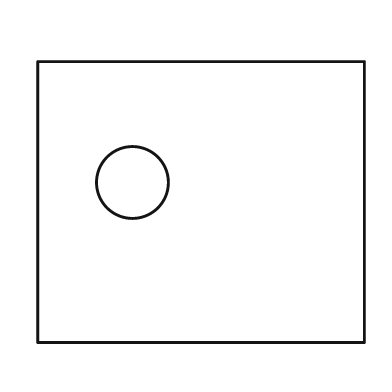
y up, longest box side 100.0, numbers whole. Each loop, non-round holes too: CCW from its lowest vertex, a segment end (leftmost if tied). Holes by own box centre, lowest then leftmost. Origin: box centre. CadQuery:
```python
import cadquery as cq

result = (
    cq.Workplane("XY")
    .moveTo(-50.0, -43.0)
    .lineTo(50.0, -43.0)
    .lineTo(50.0, 43.0)
    .lineTo(-50.0, 43.0)
    .close()
    .moveTo(-21.0, 6.0)
    .circle(11.0)
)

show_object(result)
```